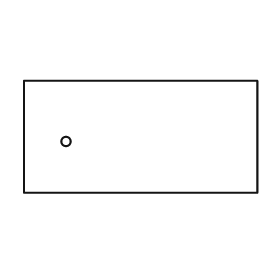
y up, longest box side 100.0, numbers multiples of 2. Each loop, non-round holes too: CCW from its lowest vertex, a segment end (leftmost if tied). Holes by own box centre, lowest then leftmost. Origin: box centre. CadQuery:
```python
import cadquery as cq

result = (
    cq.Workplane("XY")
    .moveTo(-50.0, -24.0)
    .lineTo(50.0, -24.0)
    .lineTo(50.0, 24.0)
    .lineTo(-50.0, 24.0)
    .close()
    .moveTo(-32.0, -2.0)
    .circle(2.0)
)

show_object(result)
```